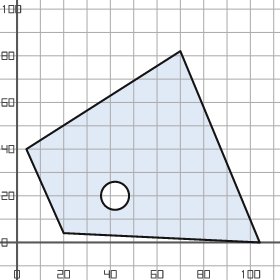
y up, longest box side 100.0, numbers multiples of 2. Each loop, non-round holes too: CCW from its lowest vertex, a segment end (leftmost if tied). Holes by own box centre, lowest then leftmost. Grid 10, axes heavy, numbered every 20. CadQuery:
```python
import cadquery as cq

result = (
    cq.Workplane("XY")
    .moveTo(104.0, 0.0)
    .lineTo(70.0, 82.0)
    .lineTo(4.0, 40.0)
    .lineTo(20.0, 4.0)
    .close()
    .moveTo(42.0, 20.0)
    .circle(6.0)
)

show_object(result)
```